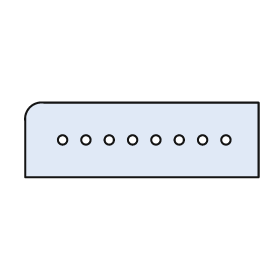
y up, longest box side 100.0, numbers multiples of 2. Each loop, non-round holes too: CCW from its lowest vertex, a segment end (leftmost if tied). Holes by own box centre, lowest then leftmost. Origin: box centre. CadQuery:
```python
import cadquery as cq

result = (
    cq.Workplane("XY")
    .moveTo(-50.0, -16.0)
    .lineTo(50.0, -16.0)
    .lineTo(50.0, 16.0)
    .lineTo(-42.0, 16.0)
    .threePointArc((-48.0, 14.0), (-50.0, 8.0))
    .close()
    .moveTo(-34.0, 0.0)
    .circle(2.0)
    .moveTo(-24.0, 0.0)
    .circle(2.0)
    .moveTo(-14.0, 0.0)
    .circle(2.0)
    .moveTo(-4.0, 0.0)
    .circle(2.0)
    .moveTo(6.0, 0.0)
    .circle(2.0)
    .moveTo(16.0, 0.0)
    .circle(2.0)
    .moveTo(26.0, 0.0)
    .circle(2.0)
    .moveTo(36.0, 0.0)
    .circle(2.0)
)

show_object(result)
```